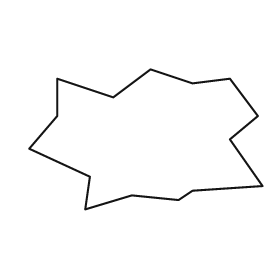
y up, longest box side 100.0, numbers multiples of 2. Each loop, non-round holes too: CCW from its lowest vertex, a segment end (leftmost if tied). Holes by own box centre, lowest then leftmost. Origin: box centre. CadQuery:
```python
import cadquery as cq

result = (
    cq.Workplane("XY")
    .moveTo(-26.0, -30.0)
    .lineTo(-6.0, -24.0)
    .lineTo(14.0, -26.0)
    .lineTo(20.0, -22.0)
    .lineTo(50.0, -20.0)
    .lineTo(36.0, 0.0)
    .lineTo(48.0, 10.0)
    .lineTo(36.0, 26.0)
    .lineTo(20.0, 24.0)
    .lineTo(2.0, 30.0)
    .lineTo(-14.0, 18.0)
    .lineTo(-38.0, 26.0)
    .lineTo(-38.0, 10.0)
    .lineTo(-50.0, -4.0)
    .lineTo(-24.0, -16.0)
    .close()
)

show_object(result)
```